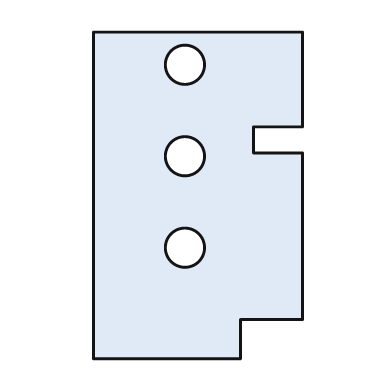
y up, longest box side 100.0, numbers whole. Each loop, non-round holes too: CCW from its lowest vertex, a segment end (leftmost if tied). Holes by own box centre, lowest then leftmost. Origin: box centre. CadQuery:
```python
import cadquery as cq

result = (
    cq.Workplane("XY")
    .moveTo(-32.0, -50.0)
    .lineTo(13.0, -50.0)
    .lineTo(13.0, -38.0)
    .lineTo(32.0, -38.0)
    .lineTo(32.0, 13.0)
    .lineTo(17.0, 13.0)
    .lineTo(17.0, 21.0)
    .lineTo(32.0, 21.0)
    .lineTo(32.0, 50.0)
    .lineTo(-32.0, 50.0)
    .close()
    .moveTo(-4.0, -16.0)
    .circle(6.0)
    .moveTo(-4.0, 12.0)
    .circle(6.0)
    .moveTo(-4.0, 40.0)
    .circle(6.0)
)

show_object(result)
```